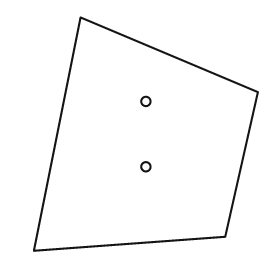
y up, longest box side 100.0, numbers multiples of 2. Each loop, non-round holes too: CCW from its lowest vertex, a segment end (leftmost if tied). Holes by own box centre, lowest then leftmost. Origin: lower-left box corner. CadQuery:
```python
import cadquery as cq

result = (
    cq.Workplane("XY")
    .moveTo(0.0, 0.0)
    .lineTo(82.0, 6.0)
    .lineTo(96.0, 68.0)
    .lineTo(20.0, 100.0)
    .close()
    .moveTo(48.0, 36.0)
    .circle(2.0)
    .moveTo(48.0, 64.0)
    .circle(2.0)
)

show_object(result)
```